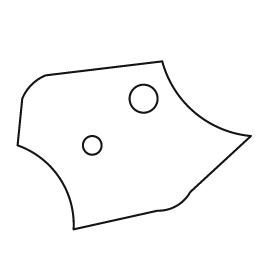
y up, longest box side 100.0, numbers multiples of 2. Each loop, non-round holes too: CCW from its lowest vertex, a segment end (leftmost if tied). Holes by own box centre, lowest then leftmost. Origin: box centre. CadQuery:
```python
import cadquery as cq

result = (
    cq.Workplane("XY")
    .moveTo(-26.0, -36.0)
    .lineTo(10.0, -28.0)
    .threePointArc((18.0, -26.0), (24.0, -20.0))
    .lineTo(50.0, 4.0)
    .threePointArc((26.0, 14.0), (12.0, 36.0))
    .lineTo(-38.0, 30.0)
    .threePointArc((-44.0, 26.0), (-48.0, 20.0))
    .lineTo(-50.0, 0.0)
    .threePointArc((-32.0, -14.0), (-26.0, -36.0))
    .close()
    .moveTo(-18.0, 0.0)
    .circle(4.0)
    .moveTo(4.0, 20.0)
    .circle(6.0)
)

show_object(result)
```